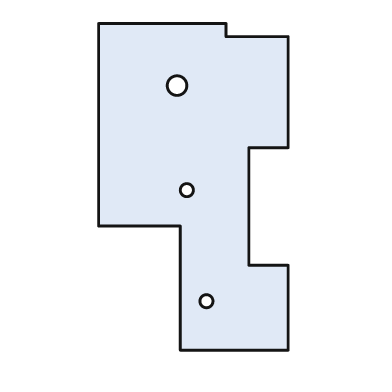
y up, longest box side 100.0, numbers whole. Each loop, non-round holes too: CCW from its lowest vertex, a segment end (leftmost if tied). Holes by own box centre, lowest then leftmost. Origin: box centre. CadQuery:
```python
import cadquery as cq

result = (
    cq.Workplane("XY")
    .moveTo(-4.0, -50.0)
    .lineTo(29.0, -50.0)
    .lineTo(29.0, -24.0)
    .lineTo(17.0, -24.0)
    .lineTo(17.0, 12.0)
    .lineTo(29.0, 12.0)
    .lineTo(29.0, 46.0)
    .lineTo(10.0, 46.0)
    .lineTo(10.0, 50.0)
    .lineTo(-29.0, 50.0)
    .lineTo(-29.0, -12.0)
    .lineTo(-4.0, -12.0)
    .close()
    .moveTo(4.0, -35.0)
    .circle(2.0)
    .moveTo(-2.0, -1.0)
    .circle(2.0)
    .moveTo(-5.0, 31.0)
    .circle(3.0)
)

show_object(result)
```